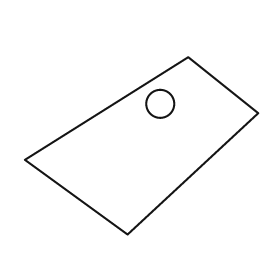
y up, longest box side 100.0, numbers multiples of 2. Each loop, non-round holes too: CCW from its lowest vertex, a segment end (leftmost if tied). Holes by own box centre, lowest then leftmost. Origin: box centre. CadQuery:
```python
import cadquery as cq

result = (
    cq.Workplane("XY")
    .moveTo(-6.0, -38.0)
    .lineTo(50.0, 14.0)
    .lineTo(20.0, 38.0)
    .lineTo(-50.0, -6.0)
    .close()
    .moveTo(8.0, 18.0)
    .circle(6.0)
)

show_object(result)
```